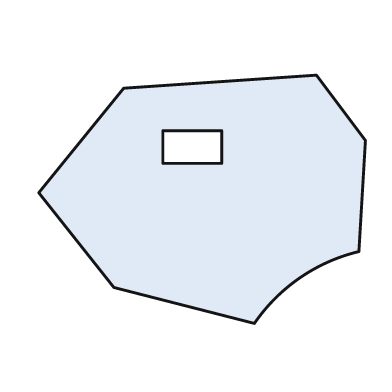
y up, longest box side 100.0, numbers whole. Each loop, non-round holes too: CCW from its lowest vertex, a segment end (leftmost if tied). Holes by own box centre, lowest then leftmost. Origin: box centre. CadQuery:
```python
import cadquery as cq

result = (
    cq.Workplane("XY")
    .moveTo(16.0, -38.0)
    .threePointArc((30.0, -24.0), (48.0, -16.0))
    .lineTo(50.0, 18.0)
    .lineTo(35.0, 38.0)
    .lineTo(-24.0, 34.0)
    .lineTo(-50.0, 2.0)
    .lineTo(-27.0, -27.0)
    .close()
    .moveTo(-12.0, 11.0)
    .lineTo(6.0, 11.0)
    .lineTo(6.0, 21.0)
    .lineTo(-12.0, 21.0)
    .close()
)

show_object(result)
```